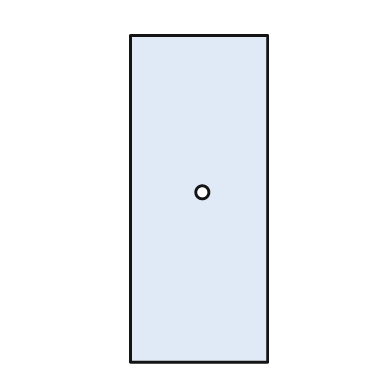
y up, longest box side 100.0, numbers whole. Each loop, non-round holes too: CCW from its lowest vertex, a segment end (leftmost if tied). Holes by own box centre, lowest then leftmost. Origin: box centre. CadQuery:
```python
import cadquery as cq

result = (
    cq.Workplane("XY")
    .moveTo(-21.0, -50.0)
    .lineTo(21.0, -50.0)
    .lineTo(21.0, 50.0)
    .lineTo(-21.0, 50.0)
    .close()
    .moveTo(1.0, 2.0)
    .circle(2.0)
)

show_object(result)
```